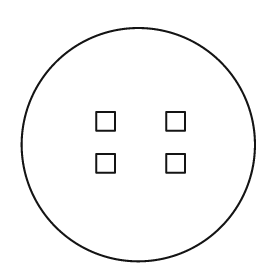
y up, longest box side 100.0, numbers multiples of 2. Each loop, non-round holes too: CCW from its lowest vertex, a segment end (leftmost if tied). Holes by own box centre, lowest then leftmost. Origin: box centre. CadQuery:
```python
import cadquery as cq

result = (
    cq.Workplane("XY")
    .moveTo(0.0, 0.0)
    .circle(50.0)
    .moveTo(-18.0, -12.0)
    .lineTo(-10.0, -12.0)
    .lineTo(-10.0, -4.0)
    .lineTo(-18.0, -4.0)
    .close()
    .moveTo(12.0, -12.0)
    .lineTo(20.0, -12.0)
    .lineTo(20.0, -4.0)
    .lineTo(12.0, -4.0)
    .close()
    .moveTo(-18.0, 6.0)
    .lineTo(-10.0, 6.0)
    .lineTo(-10.0, 14.0)
    .lineTo(-18.0, 14.0)
    .close()
    .moveTo(12.0, 6.0)
    .lineTo(20.0, 6.0)
    .lineTo(20.0, 14.0)
    .lineTo(12.0, 14.0)
    .close()
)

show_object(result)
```